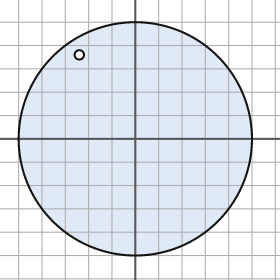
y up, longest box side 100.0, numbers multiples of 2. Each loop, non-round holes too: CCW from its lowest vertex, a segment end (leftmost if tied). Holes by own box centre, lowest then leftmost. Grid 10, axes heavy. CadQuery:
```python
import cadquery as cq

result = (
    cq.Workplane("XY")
    .moveTo(0.0, 0.0)
    .circle(50.0)
    .moveTo(-24.0, 36.0)
    .circle(2.0)
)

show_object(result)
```